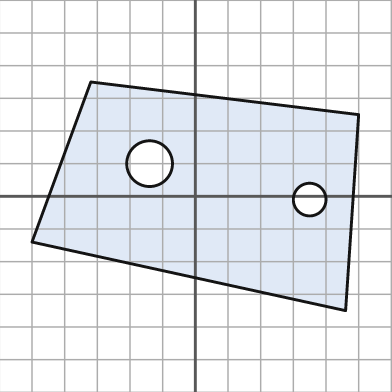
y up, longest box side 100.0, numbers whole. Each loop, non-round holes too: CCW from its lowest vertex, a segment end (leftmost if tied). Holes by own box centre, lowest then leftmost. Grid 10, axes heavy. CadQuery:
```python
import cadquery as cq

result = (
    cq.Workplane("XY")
    .moveTo(46.0, -35.0)
    .lineTo(50.0, 25.0)
    .lineTo(-32.0, 35.0)
    .lineTo(-50.0, -14.0)
    .close()
    .moveTo(35.0, -1.0)
    .circle(5.0)
    .moveTo(-14.0, 10.0)
    .circle(7.0)
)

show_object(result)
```